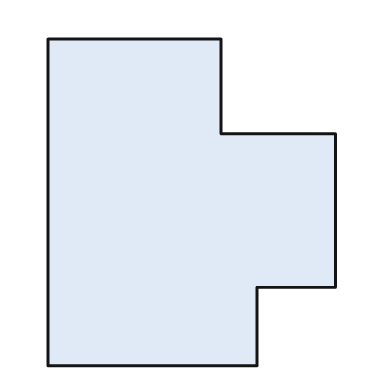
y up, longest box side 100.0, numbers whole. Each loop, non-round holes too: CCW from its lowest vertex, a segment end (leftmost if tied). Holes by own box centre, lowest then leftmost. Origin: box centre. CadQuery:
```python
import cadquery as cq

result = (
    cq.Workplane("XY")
    .moveTo(-44.0, -50.0)
    .lineTo(20.0, -50.0)
    .lineTo(20.0, -26.0)
    .lineTo(44.0, -26.0)
    .lineTo(44.0, 21.0)
    .lineTo(9.0, 21.0)
    .lineTo(9.0, 50.0)
    .lineTo(-44.0, 50.0)
    .close()
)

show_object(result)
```